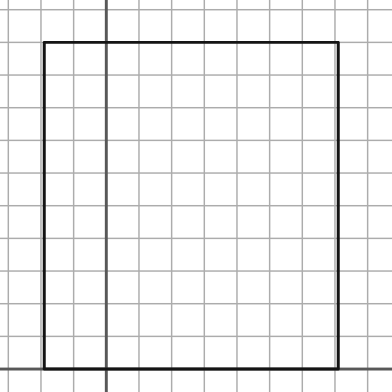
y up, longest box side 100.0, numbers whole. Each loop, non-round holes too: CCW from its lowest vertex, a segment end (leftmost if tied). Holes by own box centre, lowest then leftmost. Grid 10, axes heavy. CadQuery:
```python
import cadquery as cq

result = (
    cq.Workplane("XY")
    .moveTo(-19.0, 0.0)
    .lineTo(71.0, 0.0)
    .lineTo(71.0, 100.0)
    .lineTo(-19.0, 100.0)
    .close()
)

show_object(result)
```